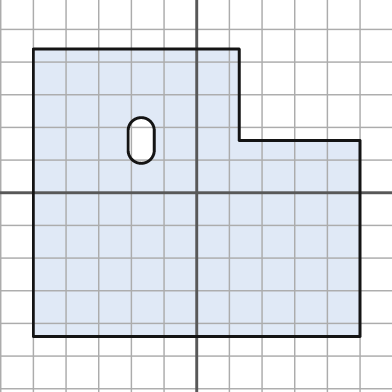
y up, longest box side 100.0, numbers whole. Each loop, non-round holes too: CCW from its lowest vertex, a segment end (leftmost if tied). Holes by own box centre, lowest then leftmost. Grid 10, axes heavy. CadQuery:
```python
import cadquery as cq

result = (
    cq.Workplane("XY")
    .moveTo(-50.0, -44.0)
    .lineTo(50.0, -44.0)
    .lineTo(50.0, 16.0)
    .lineTo(13.0, 16.0)
    .lineTo(13.0, 44.0)
    .lineTo(-50.0, 44.0)
    .close()
    .moveTo(-21.0, 13.0)
    .threePointArc((-17.0, 9.0), (-13.0, 13.0))
    .lineTo(-13.0, 19.0)
    .threePointArc((-17.0, 23.0), (-21.0, 19.0))
    .close()
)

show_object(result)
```